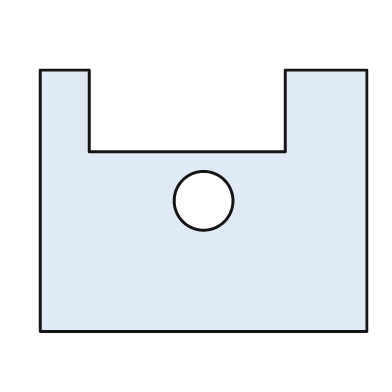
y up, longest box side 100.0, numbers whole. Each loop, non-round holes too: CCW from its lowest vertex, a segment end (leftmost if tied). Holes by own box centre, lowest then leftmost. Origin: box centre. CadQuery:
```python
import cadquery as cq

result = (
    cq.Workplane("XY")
    .moveTo(-50.0, -40.0)
    .lineTo(50.0, -40.0)
    .lineTo(50.0, 40.0)
    .lineTo(25.0, 40.0)
    .lineTo(25.0, 15.0)
    .lineTo(-35.0, 15.0)
    .lineTo(-35.0, 40.0)
    .lineTo(-50.0, 40.0)
    .close()
    .moveTo(0.0, 0.0)
    .circle(9.0)
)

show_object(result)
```